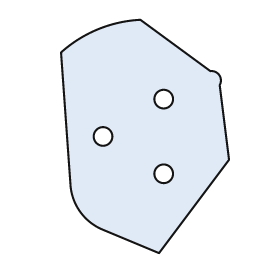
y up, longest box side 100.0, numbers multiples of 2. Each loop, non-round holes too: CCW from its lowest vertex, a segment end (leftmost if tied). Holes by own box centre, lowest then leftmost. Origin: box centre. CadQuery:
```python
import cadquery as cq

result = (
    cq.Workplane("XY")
    .moveTo(6.0, -50.0)
    .lineTo(36.0, -10.0)
    .lineTo(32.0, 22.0)
    .threePointArc((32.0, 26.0), (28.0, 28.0))
    .lineTo(-2.0, 50.0)
    .threePointArc((-20.0, 46.0), (-36.0, 36.0))
    .lineTo(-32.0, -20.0)
    .threePointArc((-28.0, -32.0), (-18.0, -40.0))
    .close()
    .moveTo(8.0, -16.0)
    .circle(4.0)
    .moveTo(-18.0, 0.0)
    .circle(4.0)
    .moveTo(8.0, 16.0)
    .circle(4.0)
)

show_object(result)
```